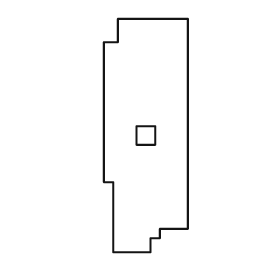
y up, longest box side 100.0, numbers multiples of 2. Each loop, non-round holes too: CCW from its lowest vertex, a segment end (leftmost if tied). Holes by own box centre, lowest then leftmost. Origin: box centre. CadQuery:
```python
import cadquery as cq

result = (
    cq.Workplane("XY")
    .moveTo(-14.0, -50.0)
    .lineTo(2.0, -50.0)
    .lineTo(2.0, -44.0)
    .lineTo(6.0, -44.0)
    .lineTo(6.0, -40.0)
    .lineTo(18.0, -40.0)
    .lineTo(18.0, 50.0)
    .lineTo(-12.0, 50.0)
    .lineTo(-12.0, 40.0)
    .lineTo(-18.0, 40.0)
    .lineTo(-18.0, -20.0)
    .lineTo(-14.0, -20.0)
    .close()
    .moveTo(-4.0, -4.0)
    .lineTo(4.0, -4.0)
    .lineTo(4.0, 4.0)
    .lineTo(-4.0, 4.0)
    .close()
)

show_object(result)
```